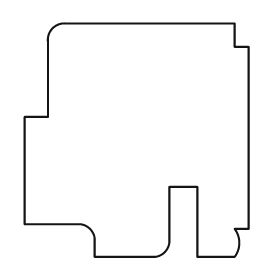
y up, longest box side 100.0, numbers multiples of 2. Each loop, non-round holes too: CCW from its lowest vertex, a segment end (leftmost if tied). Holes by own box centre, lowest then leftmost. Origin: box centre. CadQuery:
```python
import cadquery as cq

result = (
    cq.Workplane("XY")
    .moveTo(-18.0, -50.0)
    .lineTo(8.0, -50.0)
    .threePointArc((12.0, -48.0), (14.0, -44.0))
    .lineTo(14.0, -20.0)
    .lineTo(26.0, -20.0)
    .lineTo(26.0, -50.0)
    .lineTo(42.0, -50.0)
    .threePointArc((44.0, -44.0), (42.0, -38.0))
    .lineTo(48.0, -38.0)
    .lineTo(48.0, 40.0)
    .lineTo(42.0, 40.0)
    .lineTo(42.0, 50.0)
    .lineTo(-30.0, 50.0)
    .threePointArc((-36.0, 48.0), (-38.0, 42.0))
    .lineTo(-38.0, 10.0)
    .lineTo(-48.0, 10.0)
    .lineTo(-48.0, -36.0)
    .lineTo(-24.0, -36.0)
    .threePointArc((-20.0, -38.0), (-18.0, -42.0))
    .close()
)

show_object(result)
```